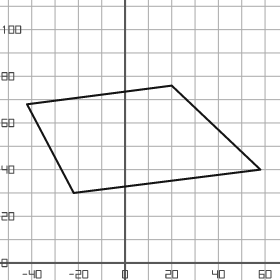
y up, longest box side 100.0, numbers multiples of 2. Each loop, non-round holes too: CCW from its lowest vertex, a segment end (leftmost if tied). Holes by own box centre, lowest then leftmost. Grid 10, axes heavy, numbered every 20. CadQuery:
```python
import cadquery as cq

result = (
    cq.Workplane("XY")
    .moveTo(-22.0, 30.0)
    .lineTo(58.0, 40.0)
    .lineTo(20.0, 76.0)
    .lineTo(-42.0, 68.0)
    .close()
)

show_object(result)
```